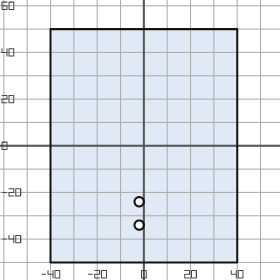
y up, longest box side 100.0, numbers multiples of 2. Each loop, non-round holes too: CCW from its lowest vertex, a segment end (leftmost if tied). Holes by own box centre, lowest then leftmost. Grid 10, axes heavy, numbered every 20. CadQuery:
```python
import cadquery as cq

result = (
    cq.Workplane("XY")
    .moveTo(-40.0, -50.0)
    .lineTo(40.0, -50.0)
    .lineTo(40.0, 50.0)
    .lineTo(-40.0, 50.0)
    .close()
    .moveTo(-2.0, -34.0)
    .circle(2.0)
    .moveTo(-2.0, -24.0)
    .circle(2.0)
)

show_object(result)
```